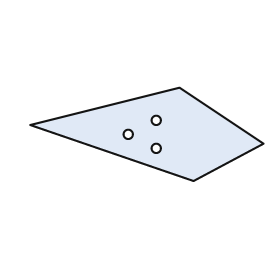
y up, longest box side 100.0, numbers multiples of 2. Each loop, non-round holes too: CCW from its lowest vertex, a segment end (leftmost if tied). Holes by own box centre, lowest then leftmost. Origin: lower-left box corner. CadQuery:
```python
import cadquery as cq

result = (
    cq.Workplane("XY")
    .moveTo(70.0, 0.0)
    .lineTo(100.0, 16.0)
    .lineTo(64.0, 40.0)
    .lineTo(0.0, 24.0)
    .close()
    .moveTo(54.0, 14.0)
    .circle(2.0)
    .moveTo(42.0, 20.0)
    .circle(2.0)
    .moveTo(54.0, 26.0)
    .circle(2.0)
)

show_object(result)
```